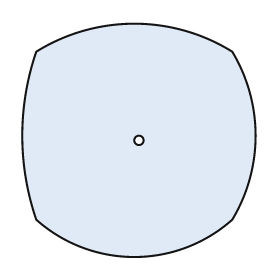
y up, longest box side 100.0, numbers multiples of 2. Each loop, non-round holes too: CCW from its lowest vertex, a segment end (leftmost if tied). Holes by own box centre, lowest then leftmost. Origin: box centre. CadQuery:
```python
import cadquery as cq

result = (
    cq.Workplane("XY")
    .moveTo(-44.0, -34.0)
    .threePointArc((-2.0, -50.0), (40.0, -34.0))
    .threePointArc((50.0, 2.0), (40.0, 38.0))
    .threePointArc((-2.0, 50.0), (-44.0, 38.0))
    .threePointArc((-50.0, 2.0), (-44.0, -34.0))
    .close()
    .moveTo(0.0, 0.0)
    .circle(2.0)
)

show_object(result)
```